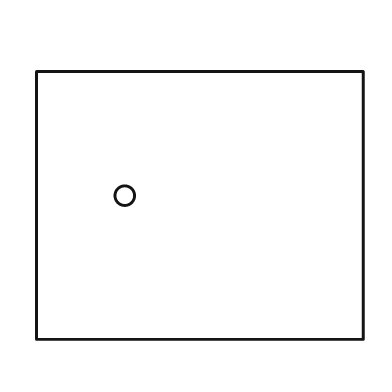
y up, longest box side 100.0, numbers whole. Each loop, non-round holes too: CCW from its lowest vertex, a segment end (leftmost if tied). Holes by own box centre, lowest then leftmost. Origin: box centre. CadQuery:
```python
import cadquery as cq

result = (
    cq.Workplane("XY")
    .moveTo(-50.0, -41.0)
    .lineTo(50.0, -41.0)
    .lineTo(50.0, 41.0)
    .lineTo(-50.0, 41.0)
    .close()
    .moveTo(-23.0, 3.0)
    .circle(3.0)
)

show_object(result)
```